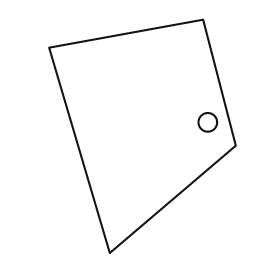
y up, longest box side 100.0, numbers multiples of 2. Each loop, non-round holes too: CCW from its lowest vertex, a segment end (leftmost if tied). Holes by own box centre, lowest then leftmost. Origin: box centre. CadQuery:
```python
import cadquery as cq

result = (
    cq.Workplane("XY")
    .moveTo(-14.0, -50.0)
    .lineTo(40.0, -4.0)
    .lineTo(26.0, 50.0)
    .lineTo(-40.0, 38.0)
    .close()
    .moveTo(28.0, 6.0)
    .circle(4.0)
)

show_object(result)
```